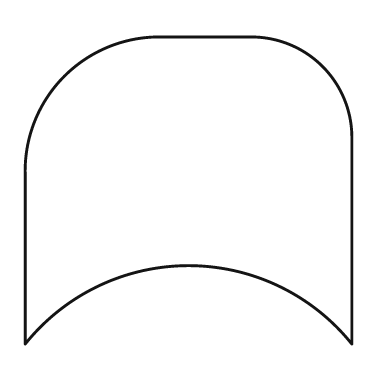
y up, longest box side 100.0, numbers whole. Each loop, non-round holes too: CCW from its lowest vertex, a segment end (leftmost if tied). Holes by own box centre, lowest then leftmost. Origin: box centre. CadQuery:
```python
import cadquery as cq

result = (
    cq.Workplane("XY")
    .moveTo(-50.0, -47.0)
    .threePointArc((0.0, -23.0), (50.0, -47.0))
    .lineTo(50.0, 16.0)
    .threePointArc((41.0, 38.0), (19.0, 47.0))
    .lineTo(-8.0, 47.0)
    .threePointArc((-38.0, 35.0), (-50.0, 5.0))
    .close()
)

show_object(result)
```